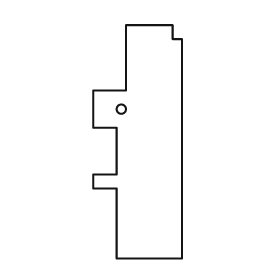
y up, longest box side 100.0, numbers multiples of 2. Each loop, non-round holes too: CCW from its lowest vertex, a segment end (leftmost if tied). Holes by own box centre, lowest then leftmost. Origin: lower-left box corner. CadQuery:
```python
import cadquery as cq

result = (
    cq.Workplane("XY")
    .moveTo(10.0, 0.0)
    .lineTo(38.0, 0.0)
    .lineTo(38.0, 94.0)
    .lineTo(34.0, 94.0)
    .lineTo(34.0, 100.0)
    .lineTo(14.0, 100.0)
    .lineTo(14.0, 72.0)
    .lineTo(0.0, 72.0)
    .lineTo(0.0, 56.0)
    .lineTo(10.0, 56.0)
    .lineTo(10.0, 36.0)
    .lineTo(0.0, 36.0)
    .lineTo(0.0, 30.0)
    .lineTo(10.0, 30.0)
    .close()
    .moveTo(12.0, 64.0)
    .circle(2.0)
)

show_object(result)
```